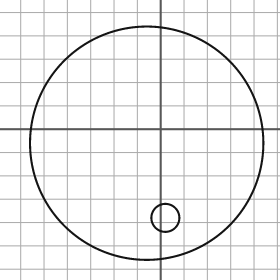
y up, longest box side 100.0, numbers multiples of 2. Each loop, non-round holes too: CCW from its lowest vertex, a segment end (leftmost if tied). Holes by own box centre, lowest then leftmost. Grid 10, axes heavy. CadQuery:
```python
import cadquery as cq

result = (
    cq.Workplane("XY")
    .moveTo(-6.0, -6.0)
    .circle(50.0)
    .moveTo(2.0, -38.0)
    .circle(6.0)
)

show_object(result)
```